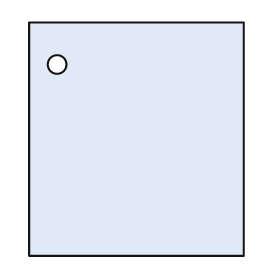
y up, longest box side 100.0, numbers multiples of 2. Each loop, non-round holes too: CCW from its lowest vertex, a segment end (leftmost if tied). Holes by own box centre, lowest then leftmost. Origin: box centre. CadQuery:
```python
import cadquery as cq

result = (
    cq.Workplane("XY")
    .moveTo(-46.0, -50.0)
    .lineTo(46.0, -50.0)
    .lineTo(46.0, 50.0)
    .lineTo(-46.0, 50.0)
    .close()
    .moveTo(-34.0, 32.0)
    .circle(4.0)
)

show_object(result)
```